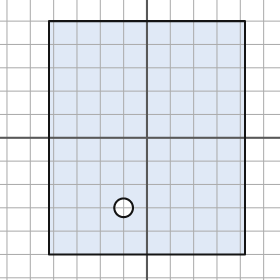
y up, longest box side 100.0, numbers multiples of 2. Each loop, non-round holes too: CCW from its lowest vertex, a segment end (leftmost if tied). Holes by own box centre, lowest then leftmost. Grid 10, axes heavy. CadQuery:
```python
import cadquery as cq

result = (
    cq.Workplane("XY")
    .moveTo(-42.0, -50.0)
    .lineTo(42.0, -50.0)
    .lineTo(42.0, 50.0)
    .lineTo(-42.0, 50.0)
    .close()
    .moveTo(-10.0, -30.0)
    .circle(4.0)
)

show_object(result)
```